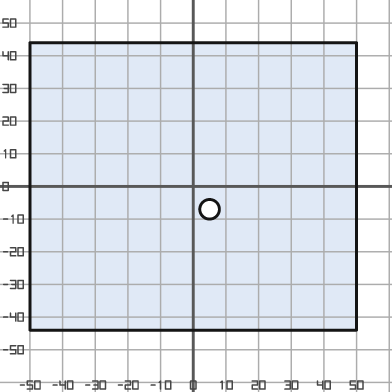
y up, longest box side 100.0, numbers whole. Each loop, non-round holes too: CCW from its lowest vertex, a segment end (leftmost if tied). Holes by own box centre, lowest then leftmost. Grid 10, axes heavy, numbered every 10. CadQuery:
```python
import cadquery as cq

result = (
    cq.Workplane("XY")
    .moveTo(-50.0, -44.0)
    .lineTo(50.0, -44.0)
    .lineTo(50.0, 44.0)
    .lineTo(-50.0, 44.0)
    .close()
    .moveTo(5.0, -7.0)
    .circle(3.0)
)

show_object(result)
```